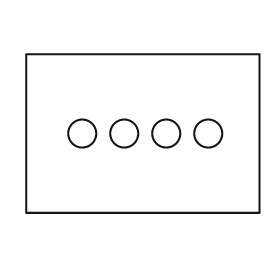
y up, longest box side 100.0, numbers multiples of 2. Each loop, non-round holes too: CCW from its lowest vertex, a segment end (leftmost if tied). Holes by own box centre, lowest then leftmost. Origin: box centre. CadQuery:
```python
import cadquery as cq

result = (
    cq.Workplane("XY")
    .moveTo(-50.0, -34.0)
    .lineTo(50.0, -34.0)
    .lineTo(50.0, 34.0)
    .lineTo(-50.0, 34.0)
    .close()
    .moveTo(-26.0, 0.0)
    .circle(6.0)
    .moveTo(-8.0, 0.0)
    .circle(6.0)
    .moveTo(10.0, 0.0)
    .circle(6.0)
    .moveTo(28.0, 0.0)
    .circle(6.0)
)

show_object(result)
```